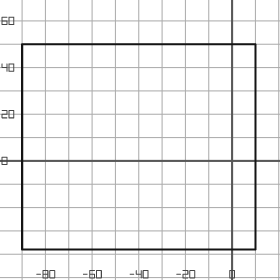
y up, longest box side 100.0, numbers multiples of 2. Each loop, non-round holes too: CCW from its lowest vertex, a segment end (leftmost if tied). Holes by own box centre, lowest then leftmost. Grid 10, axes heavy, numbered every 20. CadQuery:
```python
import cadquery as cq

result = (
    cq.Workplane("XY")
    .moveTo(-90.0, -38.0)
    .lineTo(10.0, -38.0)
    .lineTo(10.0, 50.0)
    .lineTo(-90.0, 50.0)
    .close()
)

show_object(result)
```